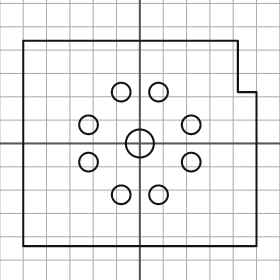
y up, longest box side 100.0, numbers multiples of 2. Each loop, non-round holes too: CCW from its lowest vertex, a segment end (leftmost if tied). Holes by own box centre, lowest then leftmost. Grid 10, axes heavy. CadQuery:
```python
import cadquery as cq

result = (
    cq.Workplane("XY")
    .moveTo(-50.0, -44.0)
    .lineTo(50.0, -44.0)
    .lineTo(50.0, 22.0)
    .lineTo(42.0, 22.0)
    .lineTo(42.0, 44.0)
    .lineTo(-50.0, 44.0)
    .close()
    .moveTo(-8.0, -22.0)
    .circle(4.0)
    .moveTo(8.0, -22.0)
    .circle(4.0)
    .moveTo(-22.0, -8.0)
    .circle(4.0)
    .moveTo(22.0, -8.0)
    .circle(4.0)
    .moveTo(0.0, 0.0)
    .circle(6.0)
    .moveTo(-22.0, 8.0)
    .circle(4.0)
    .moveTo(22.0, 8.0)
    .circle(4.0)
    .moveTo(-8.0, 22.0)
    .circle(4.0)
    .moveTo(8.0, 22.0)
    .circle(4.0)
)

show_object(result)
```